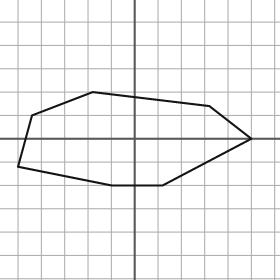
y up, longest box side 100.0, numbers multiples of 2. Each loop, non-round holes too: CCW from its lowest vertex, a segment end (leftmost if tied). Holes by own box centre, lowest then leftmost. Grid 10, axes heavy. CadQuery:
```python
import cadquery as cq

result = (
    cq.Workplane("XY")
    .moveTo(-10.0, -20.0)
    .lineTo(12.0, -20.0)
    .lineTo(50.0, 0.0)
    .lineTo(32.0, 14.0)
    .lineTo(-18.0, 20.0)
    .lineTo(-44.0, 10.0)
    .lineTo(-50.0, -12.0)
    .close()
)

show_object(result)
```